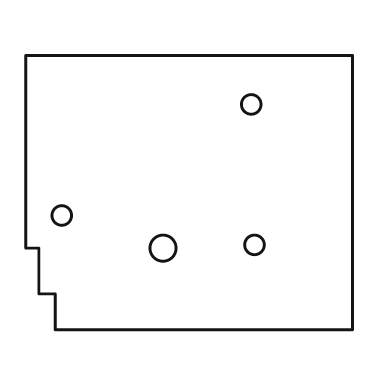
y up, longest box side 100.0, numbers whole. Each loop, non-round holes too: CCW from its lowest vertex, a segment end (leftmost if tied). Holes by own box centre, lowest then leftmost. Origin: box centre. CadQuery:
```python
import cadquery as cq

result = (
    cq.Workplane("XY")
    .moveTo(-41.0, -42.0)
    .lineTo(50.0, -42.0)
    .lineTo(50.0, 42.0)
    .lineTo(-50.0, 42.0)
    .lineTo(-50.0, -17.0)
    .lineTo(-46.0, -17.0)
    .lineTo(-46.0, -31.0)
    .lineTo(-41.0, -31.0)
    .close()
    .moveTo(-8.0, -17.0)
    .circle(4.0)
    .moveTo(20.0, -16.0)
    .circle(3.0)
    .moveTo(-39.0, -7.0)
    .circle(3.0)
    .moveTo(19.0, 27.0)
    .circle(3.0)
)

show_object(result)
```